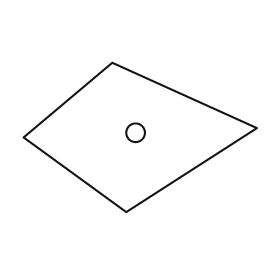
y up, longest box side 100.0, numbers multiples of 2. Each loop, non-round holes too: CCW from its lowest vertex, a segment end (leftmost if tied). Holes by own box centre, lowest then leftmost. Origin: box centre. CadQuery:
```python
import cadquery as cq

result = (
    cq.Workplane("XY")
    .moveTo(-6.0, -32.0)
    .lineTo(50.0, 4.0)
    .lineTo(-12.0, 32.0)
    .lineTo(-50.0, 0.0)
    .close()
    .moveTo(-2.0, 2.0)
    .circle(4.0)
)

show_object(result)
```